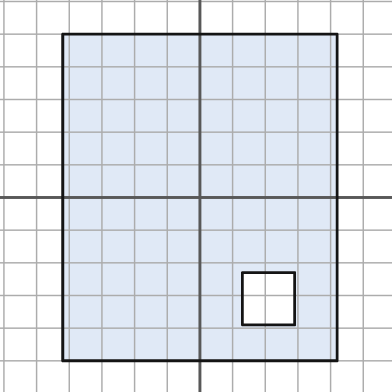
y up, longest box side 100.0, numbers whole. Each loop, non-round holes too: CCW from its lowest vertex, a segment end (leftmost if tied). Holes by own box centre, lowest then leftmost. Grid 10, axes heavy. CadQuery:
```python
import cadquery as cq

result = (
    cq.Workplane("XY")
    .moveTo(-42.0, -50.0)
    .lineTo(42.0, -50.0)
    .lineTo(42.0, 50.0)
    .lineTo(-42.0, 50.0)
    .close()
    .moveTo(13.0, -39.0)
    .lineTo(29.0, -39.0)
    .lineTo(29.0, -23.0)
    .lineTo(13.0, -23.0)
    .close()
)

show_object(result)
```